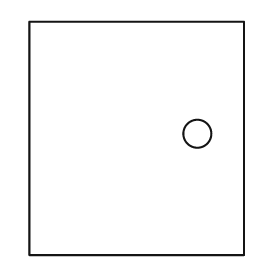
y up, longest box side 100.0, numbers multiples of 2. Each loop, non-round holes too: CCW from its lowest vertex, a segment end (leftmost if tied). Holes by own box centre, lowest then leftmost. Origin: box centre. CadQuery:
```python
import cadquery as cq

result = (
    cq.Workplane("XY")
    .moveTo(-46.0, -50.0)
    .lineTo(46.0, -50.0)
    .lineTo(46.0, 50.0)
    .lineTo(-46.0, 50.0)
    .close()
    .moveTo(26.0, 2.0)
    .circle(6.0)
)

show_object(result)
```